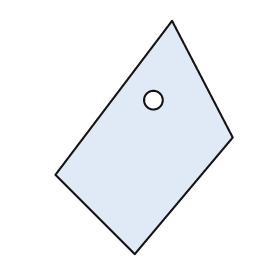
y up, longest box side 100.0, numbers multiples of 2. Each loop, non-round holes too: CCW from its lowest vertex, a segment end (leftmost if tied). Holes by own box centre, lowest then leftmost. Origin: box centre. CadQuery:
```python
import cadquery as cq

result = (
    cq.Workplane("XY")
    .moveTo(-4.0, -50.0)
    .lineTo(38.0, 0.0)
    .lineTo(12.0, 50.0)
    .lineTo(-38.0, -16.0)
    .close()
    .moveTo(4.0, 16.0)
    .circle(4.0)
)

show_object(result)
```